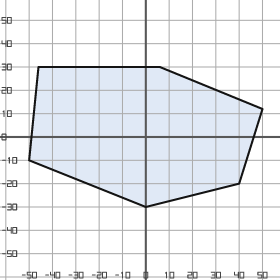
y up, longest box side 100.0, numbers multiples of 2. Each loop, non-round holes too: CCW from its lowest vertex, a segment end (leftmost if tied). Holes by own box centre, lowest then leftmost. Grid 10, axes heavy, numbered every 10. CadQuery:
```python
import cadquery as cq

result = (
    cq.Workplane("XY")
    .moveTo(0.0, -30.0)
    .lineTo(40.0, -20.0)
    .lineTo(50.0, 12.0)
    .lineTo(6.0, 30.0)
    .lineTo(-46.0, 30.0)
    .lineTo(-50.0, -10.0)
    .close()
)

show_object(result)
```